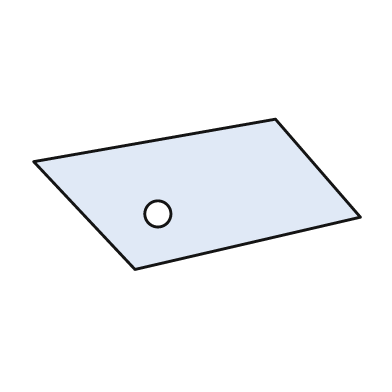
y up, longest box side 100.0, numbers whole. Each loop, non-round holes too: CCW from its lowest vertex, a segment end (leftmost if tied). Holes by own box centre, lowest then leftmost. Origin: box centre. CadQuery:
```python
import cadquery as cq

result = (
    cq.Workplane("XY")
    .moveTo(-19.0, -23.0)
    .lineTo(50.0, -7.0)
    .lineTo(24.0, 23.0)
    .lineTo(-50.0, 10.0)
    .close()
    .moveTo(-12.0, -6.0)
    .circle(4.0)
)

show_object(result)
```